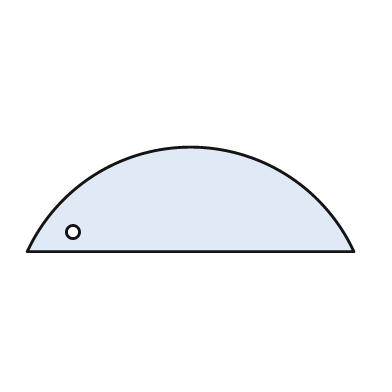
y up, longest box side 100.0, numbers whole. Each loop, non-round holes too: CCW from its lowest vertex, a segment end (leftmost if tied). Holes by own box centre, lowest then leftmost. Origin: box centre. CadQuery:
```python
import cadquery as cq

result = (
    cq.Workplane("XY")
    .moveTo(-50.0, -16.0)
    .lineTo(50.0, -16.0)
    .threePointArc((0.0, 16.0), (-50.0, -16.0))
    .close()
    .moveTo(-36.0, -10.0)
    .circle(2.0)
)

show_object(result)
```